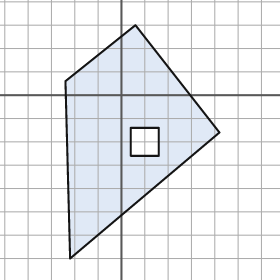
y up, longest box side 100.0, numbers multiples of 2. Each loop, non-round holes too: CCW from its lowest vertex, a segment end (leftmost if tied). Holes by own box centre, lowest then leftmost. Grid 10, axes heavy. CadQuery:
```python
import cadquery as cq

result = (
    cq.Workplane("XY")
    .moveTo(-22.0, -70.0)
    .lineTo(42.0, -16.0)
    .lineTo(6.0, 30.0)
    .lineTo(-24.0, 6.0)
    .close()
    .moveTo(4.0, -26.0)
    .lineTo(16.0, -26.0)
    .lineTo(16.0, -14.0)
    .lineTo(4.0, -14.0)
    .close()
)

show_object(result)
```